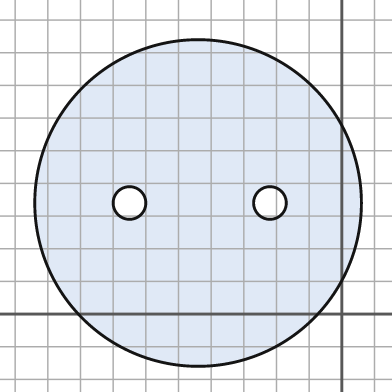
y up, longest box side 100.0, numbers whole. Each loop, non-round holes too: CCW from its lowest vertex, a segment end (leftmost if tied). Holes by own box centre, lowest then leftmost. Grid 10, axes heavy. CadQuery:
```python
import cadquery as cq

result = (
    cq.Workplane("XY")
    .moveTo(-44.0, 34.0)
    .circle(50.0)
    .moveTo(-65.0, 34.0)
    .circle(5.0)
    .moveTo(-22.0, 34.0)
    .circle(5.0)
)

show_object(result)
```